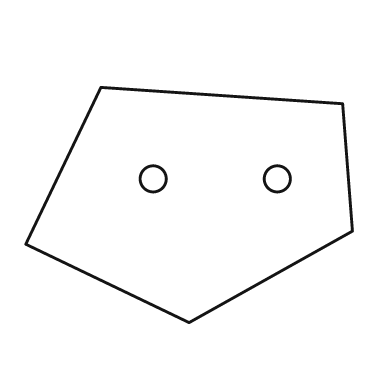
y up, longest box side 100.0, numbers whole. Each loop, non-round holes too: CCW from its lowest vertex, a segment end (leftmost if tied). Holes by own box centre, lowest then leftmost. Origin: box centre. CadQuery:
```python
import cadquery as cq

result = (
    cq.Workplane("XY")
    .moveTo(0.0, -36.0)
    .lineTo(50.0, -8.0)
    .lineTo(47.0, 31.0)
    .lineTo(-27.0, 36.0)
    .lineTo(-50.0, -12.0)
    .close()
    .moveTo(-11.0, 8.0)
    .circle(4.0)
    .moveTo(27.0, 8.0)
    .circle(4.0)
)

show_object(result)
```